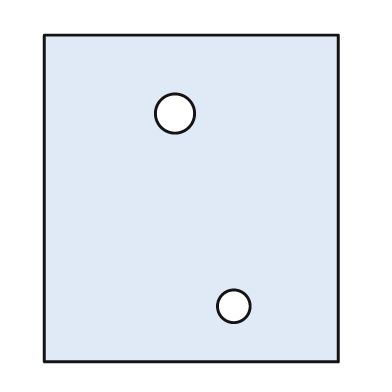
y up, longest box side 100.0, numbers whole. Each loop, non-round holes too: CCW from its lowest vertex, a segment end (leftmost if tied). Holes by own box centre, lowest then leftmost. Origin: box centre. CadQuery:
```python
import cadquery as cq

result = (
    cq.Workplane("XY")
    .moveTo(-45.0, -50.0)
    .lineTo(45.0, -50.0)
    .lineTo(45.0, 50.0)
    .lineTo(-45.0, 50.0)
    .close()
    .moveTo(13.0, -33.0)
    .circle(5.0)
    .moveTo(-5.0, 26.0)
    .circle(6.0)
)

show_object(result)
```